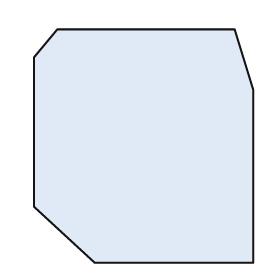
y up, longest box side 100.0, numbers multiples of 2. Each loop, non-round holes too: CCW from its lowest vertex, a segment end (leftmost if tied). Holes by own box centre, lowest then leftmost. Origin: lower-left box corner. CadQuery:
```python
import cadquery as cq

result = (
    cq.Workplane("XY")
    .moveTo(26.0, 0.0)
    .lineTo(94.0, 0.0)
    .lineTo(94.0, 74.0)
    .lineTo(86.0, 100.0)
    .lineTo(10.0, 100.0)
    .lineTo(0.0, 88.0)
    .lineTo(0.0, 24.0)
    .close()
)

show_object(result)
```